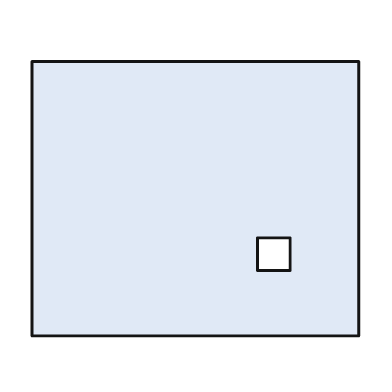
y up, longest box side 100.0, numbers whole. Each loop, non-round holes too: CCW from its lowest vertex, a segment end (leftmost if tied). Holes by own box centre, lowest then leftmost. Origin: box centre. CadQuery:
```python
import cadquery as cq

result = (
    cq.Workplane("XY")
    .moveTo(-50.0, -42.0)
    .lineTo(50.0, -42.0)
    .lineTo(50.0, 42.0)
    .lineTo(-50.0, 42.0)
    .close()
    .moveTo(19.0, -22.0)
    .lineTo(29.0, -22.0)
    .lineTo(29.0, -12.0)
    .lineTo(19.0, -12.0)
    .close()
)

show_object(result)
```